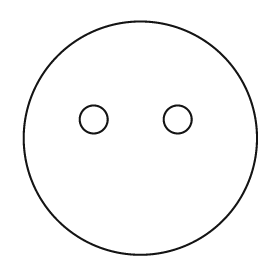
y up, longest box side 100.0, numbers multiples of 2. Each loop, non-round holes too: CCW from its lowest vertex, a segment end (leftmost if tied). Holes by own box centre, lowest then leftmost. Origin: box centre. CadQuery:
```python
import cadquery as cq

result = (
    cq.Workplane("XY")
    .moveTo(0.0, 0.0)
    .circle(50.0)
    .moveTo(-20.0, 8.0)
    .circle(6.0)
    .moveTo(16.0, 8.0)
    .circle(6.0)
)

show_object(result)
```